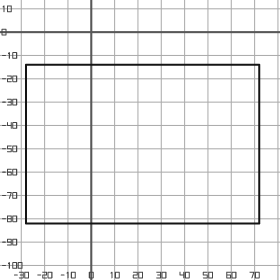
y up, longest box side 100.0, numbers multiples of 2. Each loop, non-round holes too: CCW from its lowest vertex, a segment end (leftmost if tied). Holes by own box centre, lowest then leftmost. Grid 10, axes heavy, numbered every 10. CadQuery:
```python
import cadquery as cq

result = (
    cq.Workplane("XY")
    .moveTo(-28.0, -82.0)
    .lineTo(72.0, -82.0)
    .lineTo(72.0, -14.0)
    .lineTo(-28.0, -14.0)
    .close()
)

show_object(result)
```